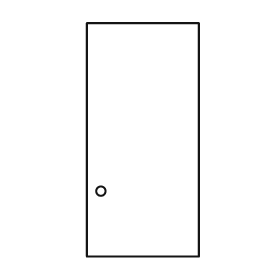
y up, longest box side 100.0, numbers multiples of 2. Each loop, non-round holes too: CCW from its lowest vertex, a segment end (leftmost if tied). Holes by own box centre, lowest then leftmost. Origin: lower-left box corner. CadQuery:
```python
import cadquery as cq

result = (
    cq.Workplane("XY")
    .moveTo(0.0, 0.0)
    .lineTo(48.0, 0.0)
    .lineTo(48.0, 100.0)
    .lineTo(0.0, 100.0)
    .close()
    .moveTo(6.0, 28.0)
    .circle(2.0)
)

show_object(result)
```